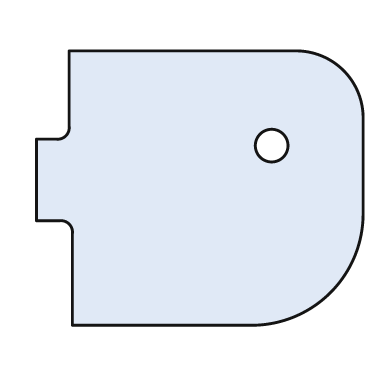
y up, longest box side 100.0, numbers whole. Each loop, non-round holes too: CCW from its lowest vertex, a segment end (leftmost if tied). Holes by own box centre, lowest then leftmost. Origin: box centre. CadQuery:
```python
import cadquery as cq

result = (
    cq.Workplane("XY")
    .moveTo(-39.0, -42.0)
    .lineTo(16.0, -42.0)
    .threePointArc((40.0, -32.0), (50.0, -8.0))
    .lineTo(50.0, 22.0)
    .threePointArc((44.0, 36.0), (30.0, 42.0))
    .lineTo(-40.0, 42.0)
    .lineTo(-40.0, 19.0)
    .threePointArc((-41.0, 16.0), (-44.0, 15.0))
    .lineTo(-50.0, 15.0)
    .lineTo(-50.0, -10.0)
    .lineTo(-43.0, -10.0)
    .threePointArc((-40.0, -11.0), (-39.0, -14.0))
    .close()
    .moveTo(22.0, 13.0)
    .circle(5.0)
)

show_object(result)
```